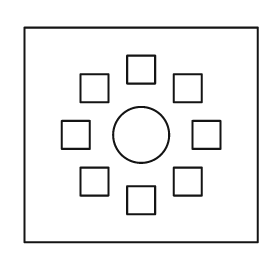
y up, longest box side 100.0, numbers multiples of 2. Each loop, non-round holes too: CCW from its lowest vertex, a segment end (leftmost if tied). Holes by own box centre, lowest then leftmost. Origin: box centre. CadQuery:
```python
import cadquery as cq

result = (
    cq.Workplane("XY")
    .moveTo(-50.0, -46.0)
    .lineTo(50.0, -46.0)
    .lineTo(50.0, 46.0)
    .lineTo(-50.0, 46.0)
    .close()
    .moveTo(-6.0, -34.0)
    .lineTo(6.0, -34.0)
    .lineTo(6.0, -22.0)
    .lineTo(-6.0, -22.0)
    .close()
    .moveTo(-26.0, -26.0)
    .lineTo(-14.0, -26.0)
    .lineTo(-14.0, -14.0)
    .lineTo(-26.0, -14.0)
    .close()
    .moveTo(14.0, -26.0)
    .lineTo(26.0, -26.0)
    .lineTo(26.0, -14.0)
    .lineTo(14.0, -14.0)
    .close()
    .moveTo(-34.0, -6.0)
    .lineTo(-22.0, -6.0)
    .lineTo(-22.0, 6.0)
    .lineTo(-34.0, 6.0)
    .close()
    .moveTo(0.0, 0.0)
    .circle(12.0)
    .moveTo(22.0, -6.0)
    .lineTo(34.0, -6.0)
    .lineTo(34.0, 6.0)
    .lineTo(22.0, 6.0)
    .close()
    .moveTo(-26.0, 14.0)
    .lineTo(-14.0, 14.0)
    .lineTo(-14.0, 26.0)
    .lineTo(-26.0, 26.0)
    .close()
    .moveTo(14.0, 14.0)
    .lineTo(26.0, 14.0)
    .lineTo(26.0, 26.0)
    .lineTo(14.0, 26.0)
    .close()
    .moveTo(-6.0, 22.0)
    .lineTo(6.0, 22.0)
    .lineTo(6.0, 34.0)
    .lineTo(-6.0, 34.0)
    .close()
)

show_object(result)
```